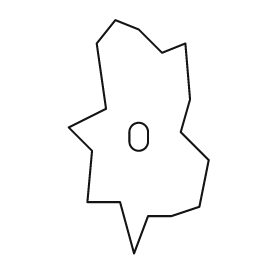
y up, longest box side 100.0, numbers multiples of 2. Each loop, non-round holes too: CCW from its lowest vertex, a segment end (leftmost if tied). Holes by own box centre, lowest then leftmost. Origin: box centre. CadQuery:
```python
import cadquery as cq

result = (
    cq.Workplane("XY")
    .moveTo(-2.0, -50.0)
    .lineTo(4.0, -34.0)
    .lineTo(14.0, -34.0)
    .lineTo(26.0, -30.0)
    .lineTo(30.0, -10.0)
    .lineTo(18.0, 2.0)
    .lineTo(22.0, 16.0)
    .lineTo(20.0, 40.0)
    .lineTo(10.0, 36.0)
    .lineTo(0.0, 46.0)
    .lineTo(-10.0, 50.0)
    .lineTo(-18.0, 40.0)
    .lineTo(-14.0, 12.0)
    .lineTo(-30.0, 4.0)
    .lineTo(-20.0, -6.0)
    .lineTo(-22.0, -28.0)
    .lineTo(-8.0, -28.0)
    .close()
    .moveTo(-4.0, -2.0)
    .threePointArc((0.0, -6.0), (4.0, -2.0))
    .lineTo(4.0, 2.0)
    .threePointArc((0.0, 6.0), (-4.0, 2.0))
    .close()
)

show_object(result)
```